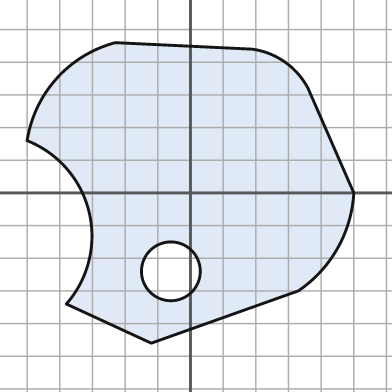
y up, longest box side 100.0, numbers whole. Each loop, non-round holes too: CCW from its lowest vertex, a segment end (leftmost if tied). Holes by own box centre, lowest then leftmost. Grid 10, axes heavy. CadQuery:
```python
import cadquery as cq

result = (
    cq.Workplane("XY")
    .moveTo(-12.0, -46.0)
    .lineTo(33.0, -30.0)
    .threePointArc((45.0, -17.0), (50.0, 0.0))
    .lineTo(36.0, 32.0)
    .threePointArc((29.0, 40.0), (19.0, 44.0))
    .lineTo(-23.0, 46.0)
    .threePointArc((-41.0, 35.0), (-50.0, 16.0))
    .threePointArc((-31.0, -6.0), (-38.0, -34.0))
    .close()
    .moveTo(-6.0, -24.0)
    .circle(9.0)
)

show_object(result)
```